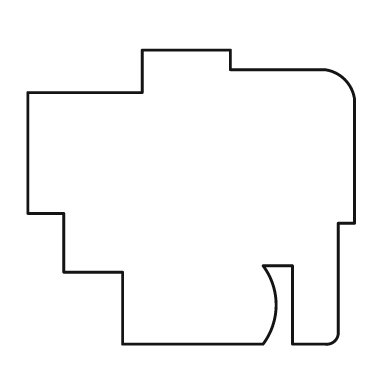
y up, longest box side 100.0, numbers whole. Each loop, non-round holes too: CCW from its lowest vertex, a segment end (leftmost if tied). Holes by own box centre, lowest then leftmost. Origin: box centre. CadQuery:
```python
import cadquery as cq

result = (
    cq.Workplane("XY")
    .moveTo(-21.0, -45.0)
    .lineTo(22.0, -45.0)
    .threePointArc((26.0, -33.0), (22.0, -21.0))
    .lineTo(31.0, -21.0)
    .lineTo(31.0, -45.0)
    .lineTo(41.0, -45.0)
    .threePointArc((44.0, -44.0), (45.0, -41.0))
    .lineTo(45.0, -8.0)
    .lineTo(50.0, -8.0)
    .lineTo(50.0, 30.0)
    .threePointArc((47.0, 36.0), (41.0, 39.0))
    .lineTo(12.0, 39.0)
    .lineTo(12.0, 45.0)
    .lineTo(-15.0, 45.0)
    .lineTo(-15.0, 32.0)
    .lineTo(-50.0, 32.0)
    .lineTo(-50.0, -5.0)
    .lineTo(-39.0, -5.0)
    .lineTo(-39.0, -23.0)
    .lineTo(-21.0, -23.0)
    .close()
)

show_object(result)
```